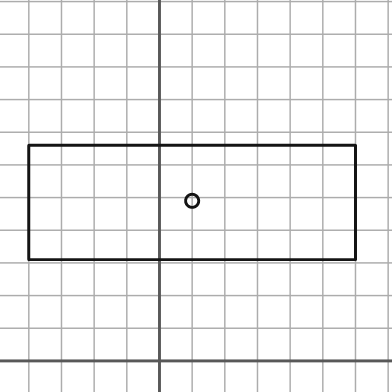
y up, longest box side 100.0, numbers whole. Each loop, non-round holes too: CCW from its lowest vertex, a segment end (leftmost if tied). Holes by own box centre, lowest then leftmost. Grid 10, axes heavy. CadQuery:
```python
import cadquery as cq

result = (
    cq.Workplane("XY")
    .moveTo(-40.0, 31.0)
    .lineTo(60.0, 31.0)
    .lineTo(60.0, 66.0)
    .lineTo(-40.0, 66.0)
    .close()
    .moveTo(10.0, 49.0)
    .circle(2.0)
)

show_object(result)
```